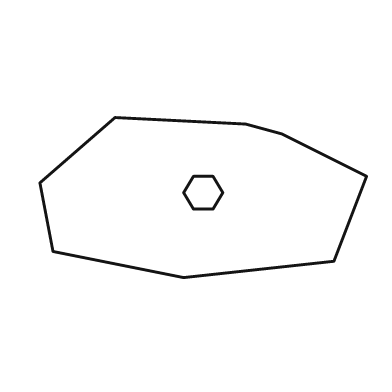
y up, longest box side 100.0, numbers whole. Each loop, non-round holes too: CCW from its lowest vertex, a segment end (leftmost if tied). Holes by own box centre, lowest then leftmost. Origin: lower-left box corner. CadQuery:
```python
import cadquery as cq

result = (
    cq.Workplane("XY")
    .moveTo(44.0, 0.0)
    .lineTo(90.0, 5.0)
    .lineTo(100.0, 31.0)
    .lineTo(74.0, 44.0)
    .lineTo(63.0, 47.0)
    .lineTo(23.0, 49.0)
    .lineTo(0.0, 29.0)
    .lineTo(4.0, 8.0)
    .close()
    .moveTo(47.0, 21.0)
    .lineTo(53.0, 21.0)
    .lineTo(56.0, 26.0)
    .lineTo(53.0, 31.0)
    .lineTo(47.0, 31.0)
    .lineTo(44.0, 26.0)
    .close()
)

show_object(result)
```